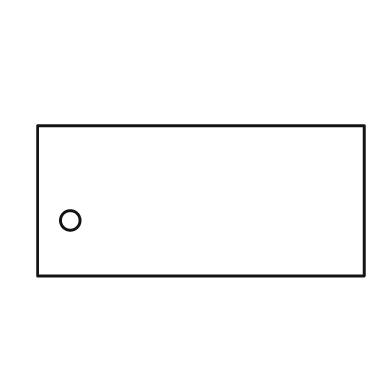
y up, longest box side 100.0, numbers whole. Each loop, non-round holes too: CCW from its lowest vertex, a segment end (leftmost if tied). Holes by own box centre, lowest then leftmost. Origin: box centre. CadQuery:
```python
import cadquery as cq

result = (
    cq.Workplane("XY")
    .moveTo(-50.0, -23.0)
    .lineTo(50.0, -23.0)
    .lineTo(50.0, 23.0)
    .lineTo(-50.0, 23.0)
    .close()
    .moveTo(-40.0, -6.0)
    .circle(3.0)
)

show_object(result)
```